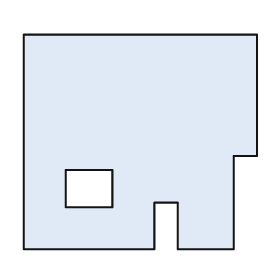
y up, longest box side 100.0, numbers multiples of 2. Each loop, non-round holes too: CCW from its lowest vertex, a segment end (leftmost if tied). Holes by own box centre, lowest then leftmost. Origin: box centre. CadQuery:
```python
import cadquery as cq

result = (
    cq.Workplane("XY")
    .moveTo(-50.0, -46.0)
    .lineTo(6.0, -46.0)
    .lineTo(6.0, -26.0)
    .lineTo(16.0, -26.0)
    .lineTo(16.0, -46.0)
    .lineTo(40.0, -46.0)
    .lineTo(40.0, -6.0)
    .lineTo(50.0, -6.0)
    .lineTo(50.0, 46.0)
    .lineTo(-50.0, 46.0)
    .close()
    .moveTo(-32.0, -28.0)
    .lineTo(-12.0, -28.0)
    .lineTo(-12.0, -12.0)
    .lineTo(-32.0, -12.0)
    .close()
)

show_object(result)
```